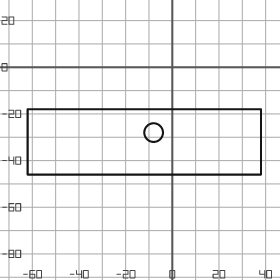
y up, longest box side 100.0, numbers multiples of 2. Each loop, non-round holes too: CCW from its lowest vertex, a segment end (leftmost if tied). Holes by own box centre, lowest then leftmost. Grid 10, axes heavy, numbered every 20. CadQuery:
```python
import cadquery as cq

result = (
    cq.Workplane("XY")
    .moveTo(-62.0, -46.0)
    .lineTo(38.0, -46.0)
    .lineTo(38.0, -18.0)
    .lineTo(-62.0, -18.0)
    .close()
    .moveTo(-8.0, -28.0)
    .circle(4.0)
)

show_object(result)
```